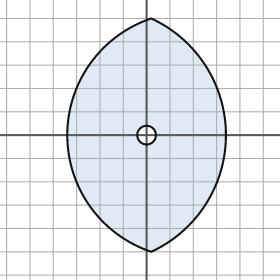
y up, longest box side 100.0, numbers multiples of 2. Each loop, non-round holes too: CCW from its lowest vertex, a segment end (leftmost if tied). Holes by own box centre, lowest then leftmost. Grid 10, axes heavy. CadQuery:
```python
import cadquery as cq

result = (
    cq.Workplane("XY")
    .moveTo(2.0, -50.0)
    .threePointArc((34.0, 0.0), (2.0, 50.0))
    .threePointArc((-34.0, 0.0), (2.0, -50.0))
    .close()
    .moveTo(0.0, 0.0)
    .circle(4.0)
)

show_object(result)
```